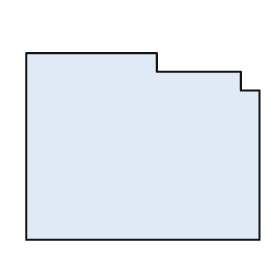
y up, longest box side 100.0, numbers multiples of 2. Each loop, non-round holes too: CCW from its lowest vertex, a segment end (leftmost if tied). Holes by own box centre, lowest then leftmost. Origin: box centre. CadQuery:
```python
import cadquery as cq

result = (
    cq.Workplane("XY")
    .moveTo(-50.0, -40.0)
    .lineTo(50.0, -40.0)
    .lineTo(50.0, 24.0)
    .lineTo(42.0, 24.0)
    .lineTo(42.0, 32.0)
    .lineTo(6.0, 32.0)
    .lineTo(6.0, 40.0)
    .lineTo(-50.0, 40.0)
    .close()
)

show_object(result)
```